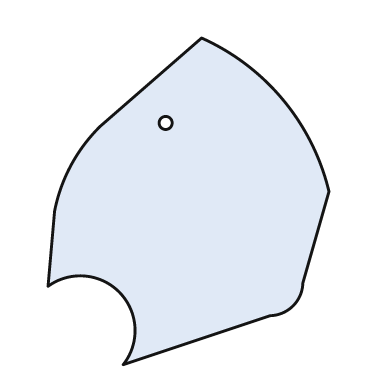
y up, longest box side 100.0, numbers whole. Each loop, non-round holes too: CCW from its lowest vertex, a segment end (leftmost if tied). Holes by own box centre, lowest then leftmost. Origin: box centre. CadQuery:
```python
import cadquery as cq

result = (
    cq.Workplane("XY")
    .moveTo(-20.0, -50.0)
    .lineTo(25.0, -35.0)
    .threePointArc((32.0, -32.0), (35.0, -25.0))
    .lineTo(43.0, 3.0)
    .threePointArc((29.0, 31.0), (4.0, 50.0))
    .lineTo(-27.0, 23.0)
    .threePointArc((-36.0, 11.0), (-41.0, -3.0))
    .lineTo(-43.0, -26.0)
    .threePointArc((-21.0, -28.0), (-20.0, -50.0))
    .close()
    .moveTo(-7.0, 24.0)
    .circle(2.0)
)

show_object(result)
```